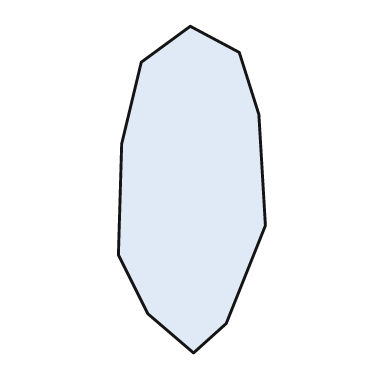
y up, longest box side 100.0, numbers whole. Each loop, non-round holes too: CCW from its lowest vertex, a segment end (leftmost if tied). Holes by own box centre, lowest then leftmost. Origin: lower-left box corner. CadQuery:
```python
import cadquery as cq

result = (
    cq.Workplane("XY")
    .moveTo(23.0, 0.0)
    .lineTo(33.0, 9.0)
    .lineTo(45.0, 39.0)
    .lineTo(43.0, 73.0)
    .lineTo(37.0, 92.0)
    .lineTo(22.0, 100.0)
    .lineTo(7.0, 89.0)
    .lineTo(1.0, 64.0)
    .lineTo(0.0, 30.0)
    .lineTo(9.0, 12.0)
    .close()
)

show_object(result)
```